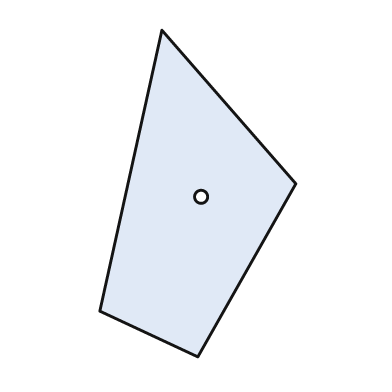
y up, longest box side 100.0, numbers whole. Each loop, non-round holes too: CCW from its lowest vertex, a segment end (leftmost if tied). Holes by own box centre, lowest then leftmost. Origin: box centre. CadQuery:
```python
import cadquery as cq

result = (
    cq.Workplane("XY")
    .moveTo(0.0, -50.0)
    .lineTo(30.0, 3.0)
    .lineTo(-11.0, 50.0)
    .lineTo(-30.0, -36.0)
    .close()
    .moveTo(1.0, -1.0)
    .circle(2.0)
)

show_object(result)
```